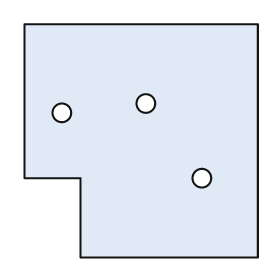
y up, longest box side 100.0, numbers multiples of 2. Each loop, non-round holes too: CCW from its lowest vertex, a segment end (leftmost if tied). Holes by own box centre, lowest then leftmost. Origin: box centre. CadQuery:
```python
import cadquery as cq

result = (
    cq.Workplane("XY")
    .moveTo(-26.0, -50.0)
    .lineTo(50.0, -50.0)
    .lineTo(50.0, 50.0)
    .lineTo(-50.0, 50.0)
    .lineTo(-50.0, -16.0)
    .lineTo(-26.0, -16.0)
    .close()
    .moveTo(26.0, -16.0)
    .circle(4.0)
    .moveTo(-34.0, 12.0)
    .circle(4.0)
    .moveTo(2.0, 16.0)
    .circle(4.0)
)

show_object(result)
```